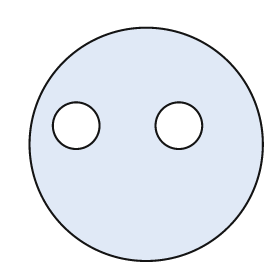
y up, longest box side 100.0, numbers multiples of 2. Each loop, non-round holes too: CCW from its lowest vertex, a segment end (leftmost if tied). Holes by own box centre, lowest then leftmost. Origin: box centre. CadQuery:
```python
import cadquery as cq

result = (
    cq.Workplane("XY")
    .moveTo(0.0, 0.0)
    .circle(50.0)
    .moveTo(-30.0, 8.0)
    .circle(10.0)
    .moveTo(14.0, 8.0)
    .circle(10.0)
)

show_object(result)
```